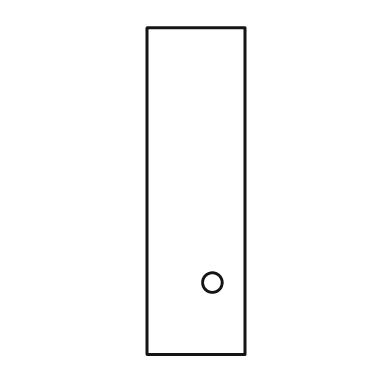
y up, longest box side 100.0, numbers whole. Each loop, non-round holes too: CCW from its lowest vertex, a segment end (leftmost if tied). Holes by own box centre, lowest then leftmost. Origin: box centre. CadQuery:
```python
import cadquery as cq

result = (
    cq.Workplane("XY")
    .moveTo(-15.0, -50.0)
    .lineTo(15.0, -50.0)
    .lineTo(15.0, 50.0)
    .lineTo(-15.0, 50.0)
    .close()
    .moveTo(5.0, -28.0)
    .circle(3.0)
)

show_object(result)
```